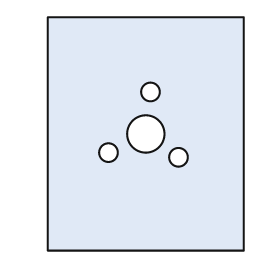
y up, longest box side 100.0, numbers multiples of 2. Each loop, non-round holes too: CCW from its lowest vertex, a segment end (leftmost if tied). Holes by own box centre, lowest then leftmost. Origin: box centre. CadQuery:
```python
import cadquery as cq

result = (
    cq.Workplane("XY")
    .moveTo(-42.0, -50.0)
    .lineTo(42.0, -50.0)
    .lineTo(42.0, 50.0)
    .lineTo(-42.0, 50.0)
    .close()
    .moveTo(14.0, -10.0)
    .circle(4.0)
    .moveTo(-16.0, -8.0)
    .circle(4.0)
    .moveTo(0.0, 0.0)
    .circle(8.0)
    .moveTo(2.0, 18.0)
    .circle(4.0)
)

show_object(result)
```